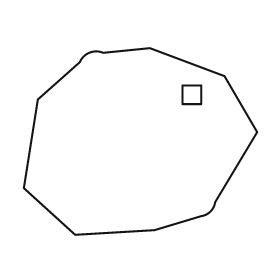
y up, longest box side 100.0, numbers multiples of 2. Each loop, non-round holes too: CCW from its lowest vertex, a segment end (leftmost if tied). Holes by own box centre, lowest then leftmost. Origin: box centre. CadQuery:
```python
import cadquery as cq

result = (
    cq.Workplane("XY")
    .moveTo(-28.0, -40.0)
    .lineTo(6.0, -38.0)
    .lineTo(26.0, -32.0)
    .threePointArc((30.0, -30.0), (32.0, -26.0))
    .lineTo(50.0, 4.0)
    .lineTo(36.0, 28.0)
    .lineTo(4.0, 40.0)
    .lineTo(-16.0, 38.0)
    .threePointArc((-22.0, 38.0), (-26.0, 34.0))
    .lineTo(-44.0, 18.0)
    .lineTo(-50.0, -20.0)
    .close()
    .moveTo(18.0, 16.0)
    .lineTo(26.0, 16.0)
    .lineTo(26.0, 24.0)
    .lineTo(18.0, 24.0)
    .close()
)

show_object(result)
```